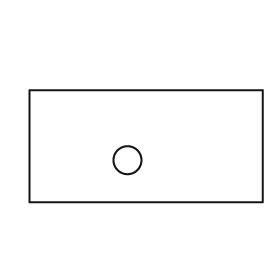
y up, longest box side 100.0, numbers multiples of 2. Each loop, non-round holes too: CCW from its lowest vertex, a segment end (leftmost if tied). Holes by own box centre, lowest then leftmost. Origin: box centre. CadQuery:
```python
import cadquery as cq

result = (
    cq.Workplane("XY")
    .moveTo(-50.0, -24.0)
    .lineTo(50.0, -24.0)
    .lineTo(50.0, 24.0)
    .lineTo(-50.0, 24.0)
    .close()
    .moveTo(-8.0, -6.0)
    .circle(6.0)
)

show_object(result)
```